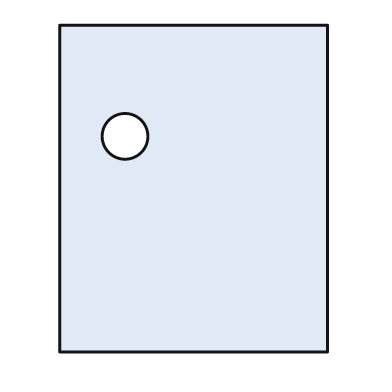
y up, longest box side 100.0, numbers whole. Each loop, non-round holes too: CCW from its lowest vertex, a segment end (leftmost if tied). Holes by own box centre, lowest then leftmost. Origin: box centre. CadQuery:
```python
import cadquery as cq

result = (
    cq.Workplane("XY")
    .moveTo(-41.0, -50.0)
    .lineTo(41.0, -50.0)
    .lineTo(41.0, 50.0)
    .lineTo(-41.0, 50.0)
    .close()
    .moveTo(-21.0, 16.0)
    .circle(7.0)
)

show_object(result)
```